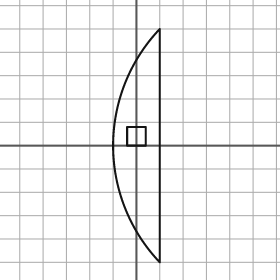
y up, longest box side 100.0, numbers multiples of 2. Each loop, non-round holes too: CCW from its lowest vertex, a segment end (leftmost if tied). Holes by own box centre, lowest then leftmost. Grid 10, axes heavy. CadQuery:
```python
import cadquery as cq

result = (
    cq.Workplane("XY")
    .moveTo(10.0, -50.0)
    .lineTo(10.0, 50.0)
    .threePointArc((-10.0, 0.0), (10.0, -50.0))
    .close()
    .moveTo(-4.0, 0.0)
    .lineTo(4.0, 0.0)
    .lineTo(4.0, 8.0)
    .lineTo(-4.0, 8.0)
    .close()
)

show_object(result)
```